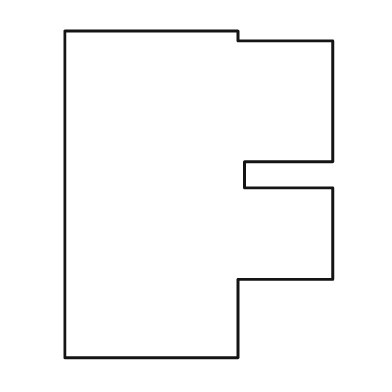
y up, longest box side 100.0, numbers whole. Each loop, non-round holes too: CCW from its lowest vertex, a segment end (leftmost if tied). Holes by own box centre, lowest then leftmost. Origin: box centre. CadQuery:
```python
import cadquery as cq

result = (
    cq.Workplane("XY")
    .moveTo(-41.0, -50.0)
    .lineTo(12.0, -50.0)
    .lineTo(12.0, -26.0)
    .lineTo(41.0, -26.0)
    .lineTo(41.0, 2.0)
    .lineTo(14.0, 2.0)
    .lineTo(14.0, 10.0)
    .lineTo(41.0, 10.0)
    .lineTo(41.0, 47.0)
    .lineTo(12.0, 47.0)
    .lineTo(12.0, 50.0)
    .lineTo(-41.0, 50.0)
    .close()
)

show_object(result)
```